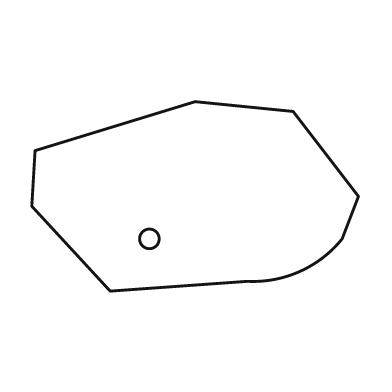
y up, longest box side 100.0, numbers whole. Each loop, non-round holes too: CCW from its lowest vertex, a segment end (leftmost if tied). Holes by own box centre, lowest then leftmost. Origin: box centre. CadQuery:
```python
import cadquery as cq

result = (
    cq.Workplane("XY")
    .moveTo(-26.0, -29.0)
    .lineTo(16.0, -26.0)
    .threePointArc((32.0, -23.0), (45.0, -13.0))
    .lineTo(50.0, 0.0)
    .lineTo(30.0, 26.0)
    .lineTo(0.0, 29.0)
    .lineTo(-49.0, 14.0)
    .lineTo(-50.0, -3.0)
    .close()
    .moveTo(-14.0, -13.0)
    .circle(3.0)
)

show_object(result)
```